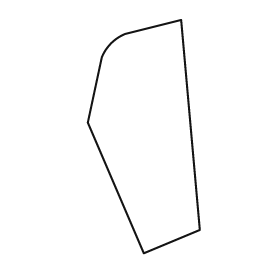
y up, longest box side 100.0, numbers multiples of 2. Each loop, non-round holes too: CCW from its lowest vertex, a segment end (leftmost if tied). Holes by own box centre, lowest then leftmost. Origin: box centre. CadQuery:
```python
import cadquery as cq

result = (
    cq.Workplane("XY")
    .moveTo(0.0, -50.0)
    .lineTo(24.0, -40.0)
    .lineTo(16.0, 50.0)
    .lineTo(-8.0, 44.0)
    .threePointArc((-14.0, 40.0), (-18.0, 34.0))
    .lineTo(-24.0, 6.0)
    .close()
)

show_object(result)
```